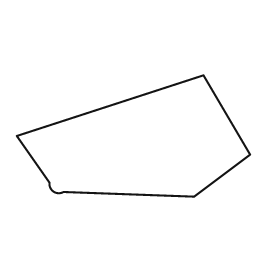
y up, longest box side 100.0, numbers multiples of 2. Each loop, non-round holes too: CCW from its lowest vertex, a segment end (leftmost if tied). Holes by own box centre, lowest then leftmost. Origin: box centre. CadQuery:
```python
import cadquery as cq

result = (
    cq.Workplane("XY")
    .moveTo(26.0, -26.0)
    .lineTo(50.0, -8.0)
    .lineTo(30.0, 26.0)
    .lineTo(-50.0, 0.0)
    .lineTo(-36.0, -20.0)
    .threePointArc((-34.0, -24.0), (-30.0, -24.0))
    .close()
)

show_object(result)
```